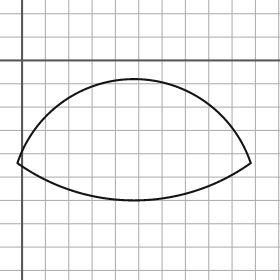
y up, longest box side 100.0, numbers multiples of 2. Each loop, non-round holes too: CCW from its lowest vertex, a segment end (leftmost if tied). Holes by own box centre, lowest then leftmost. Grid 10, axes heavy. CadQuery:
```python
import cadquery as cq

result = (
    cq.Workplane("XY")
    .moveTo(-2.0, -44.0)
    .threePointArc((48.0, -60.0), (98.0, -44.0))
    .threePointArc((48.0, -8.0), (-2.0, -44.0))
    .close()
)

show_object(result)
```